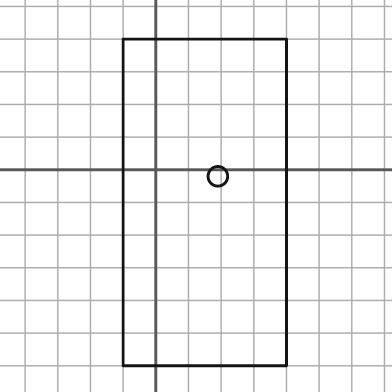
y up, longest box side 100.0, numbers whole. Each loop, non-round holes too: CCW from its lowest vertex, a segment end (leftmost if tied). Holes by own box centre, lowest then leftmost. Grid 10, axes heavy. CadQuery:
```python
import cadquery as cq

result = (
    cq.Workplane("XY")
    .moveTo(-10.0, -60.0)
    .lineTo(40.0, -60.0)
    .lineTo(40.0, 40.0)
    .lineTo(-10.0, 40.0)
    .close()
    .moveTo(19.0, -2.0)
    .circle(3.0)
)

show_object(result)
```